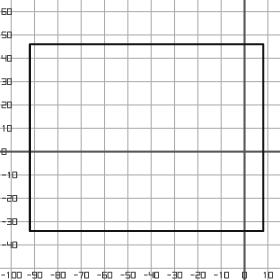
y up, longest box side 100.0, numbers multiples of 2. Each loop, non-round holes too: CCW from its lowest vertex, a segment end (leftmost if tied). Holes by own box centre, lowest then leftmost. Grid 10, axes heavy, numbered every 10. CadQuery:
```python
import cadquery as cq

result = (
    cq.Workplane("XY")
    .moveTo(-92.0, -34.0)
    .lineTo(8.0, -34.0)
    .lineTo(8.0, 46.0)
    .lineTo(-92.0, 46.0)
    .close()
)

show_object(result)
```